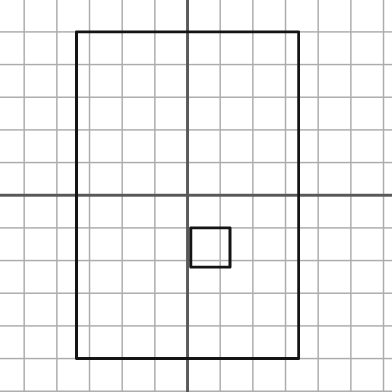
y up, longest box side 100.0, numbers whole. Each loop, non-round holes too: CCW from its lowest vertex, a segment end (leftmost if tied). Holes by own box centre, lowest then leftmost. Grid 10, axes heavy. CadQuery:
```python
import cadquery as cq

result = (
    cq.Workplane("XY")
    .moveTo(-34.0, -50.0)
    .lineTo(34.0, -50.0)
    .lineTo(34.0, 50.0)
    .lineTo(-34.0, 50.0)
    .close()
    .moveTo(1.0, -22.0)
    .lineTo(13.0, -22.0)
    .lineTo(13.0, -10.0)
    .lineTo(1.0, -10.0)
    .close()
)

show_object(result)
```